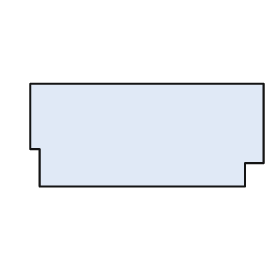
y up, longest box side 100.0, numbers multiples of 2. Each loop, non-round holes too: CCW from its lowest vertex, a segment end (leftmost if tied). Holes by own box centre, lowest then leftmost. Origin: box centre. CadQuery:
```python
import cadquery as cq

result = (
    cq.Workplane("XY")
    .moveTo(-46.0, -22.0)
    .lineTo(42.0, -22.0)
    .lineTo(42.0, -12.0)
    .lineTo(50.0, -12.0)
    .lineTo(50.0, 22.0)
    .lineTo(-50.0, 22.0)
    .lineTo(-50.0, -6.0)
    .lineTo(-46.0, -6.0)
    .close()
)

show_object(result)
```